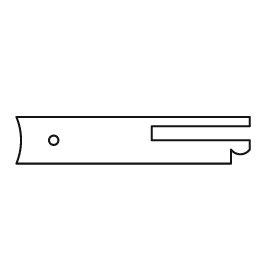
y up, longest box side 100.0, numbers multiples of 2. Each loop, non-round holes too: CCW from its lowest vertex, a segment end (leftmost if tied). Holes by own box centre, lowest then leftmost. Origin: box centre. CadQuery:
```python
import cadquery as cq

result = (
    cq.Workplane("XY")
    .moveTo(-50.0, -10.0)
    .lineTo(42.0, -10.0)
    .lineTo(42.0, -4.0)
    .threePointArc((46.0, -6.0), (50.0, -4.0))
    .lineTo(50.0, 0.0)
    .lineTo(8.0, 0.0)
    .lineTo(8.0, 6.0)
    .lineTo(50.0, 6.0)
    .lineTo(50.0, 10.0)
    .lineTo(-50.0, 10.0)
    .threePointArc((-48.0, 0.0), (-50.0, -10.0))
    .close()
    .moveTo(-34.0, 0.0)
    .circle(2.0)
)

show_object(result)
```